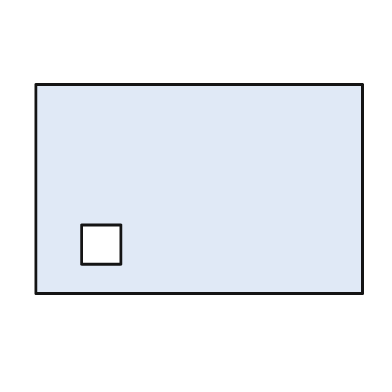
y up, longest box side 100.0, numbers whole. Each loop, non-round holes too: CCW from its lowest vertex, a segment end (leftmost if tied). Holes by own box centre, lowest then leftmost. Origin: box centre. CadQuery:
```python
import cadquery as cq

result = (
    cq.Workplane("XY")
    .moveTo(-50.0, -32.0)
    .lineTo(50.0, -32.0)
    .lineTo(50.0, 32.0)
    .lineTo(-50.0, 32.0)
    .close()
    .moveTo(-36.0, -23.0)
    .lineTo(-24.0, -23.0)
    .lineTo(-24.0, -11.0)
    .lineTo(-36.0, -11.0)
    .close()
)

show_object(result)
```